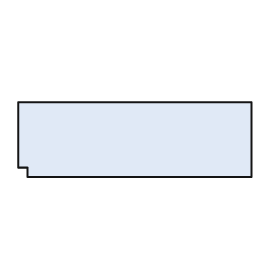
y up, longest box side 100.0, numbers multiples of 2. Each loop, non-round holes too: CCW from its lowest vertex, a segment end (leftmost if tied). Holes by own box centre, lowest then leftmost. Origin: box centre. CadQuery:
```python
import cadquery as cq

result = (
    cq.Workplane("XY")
    .moveTo(-46.0, -16.0)
    .lineTo(50.0, -16.0)
    .lineTo(50.0, 16.0)
    .lineTo(-50.0, 16.0)
    .lineTo(-50.0, -12.0)
    .lineTo(-46.0, -12.0)
    .close()
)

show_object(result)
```